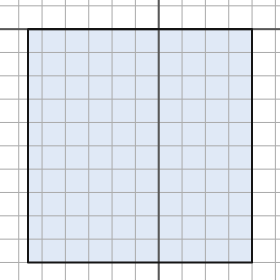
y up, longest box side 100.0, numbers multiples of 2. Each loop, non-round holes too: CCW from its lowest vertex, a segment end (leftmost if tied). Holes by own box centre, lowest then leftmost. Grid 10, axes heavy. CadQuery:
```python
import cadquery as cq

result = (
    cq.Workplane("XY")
    .moveTo(-56.0, -100.0)
    .lineTo(40.0, -100.0)
    .lineTo(40.0, 0.0)
    .lineTo(-56.0, 0.0)
    .close()
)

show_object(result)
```